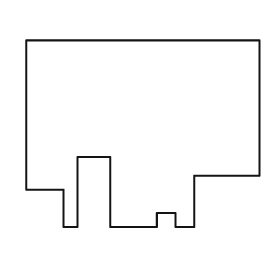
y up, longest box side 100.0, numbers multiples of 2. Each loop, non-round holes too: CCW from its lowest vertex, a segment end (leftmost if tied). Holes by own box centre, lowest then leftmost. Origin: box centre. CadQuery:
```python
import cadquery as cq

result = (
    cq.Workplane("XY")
    .moveTo(-34.0, -40.0)
    .lineTo(-28.0, -40.0)
    .lineTo(-28.0, -10.0)
    .lineTo(-14.0, -10.0)
    .lineTo(-14.0, -40.0)
    .lineTo(6.0, -40.0)
    .lineTo(6.0, -34.0)
    .lineTo(14.0, -34.0)
    .lineTo(14.0, -40.0)
    .lineTo(22.0, -40.0)
    .lineTo(22.0, -18.0)
    .lineTo(50.0, -18.0)
    .lineTo(50.0, 40.0)
    .lineTo(-50.0, 40.0)
    .lineTo(-50.0, -24.0)
    .lineTo(-34.0, -24.0)
    .close()
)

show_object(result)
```